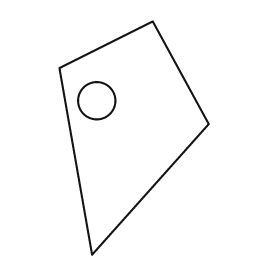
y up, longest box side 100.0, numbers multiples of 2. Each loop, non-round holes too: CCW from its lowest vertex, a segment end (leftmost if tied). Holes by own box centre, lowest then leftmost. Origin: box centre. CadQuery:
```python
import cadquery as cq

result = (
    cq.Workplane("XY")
    .moveTo(-18.0, -50.0)
    .lineTo(32.0, 6.0)
    .lineTo(8.0, 50.0)
    .lineTo(-32.0, 30.0)
    .close()
    .moveTo(-16.0, 16.0)
    .circle(8.0)
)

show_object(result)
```